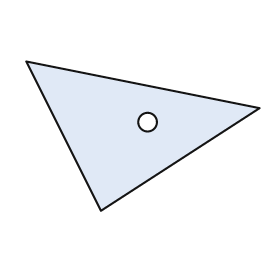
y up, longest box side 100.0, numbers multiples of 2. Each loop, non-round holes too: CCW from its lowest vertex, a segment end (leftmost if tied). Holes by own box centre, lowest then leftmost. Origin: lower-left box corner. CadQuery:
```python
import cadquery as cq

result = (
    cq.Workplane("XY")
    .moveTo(32.0, 0.0)
    .lineTo(100.0, 44.0)
    .lineTo(0.0, 64.0)
    .close()
    .moveTo(52.0, 38.0)
    .circle(4.0)
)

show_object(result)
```